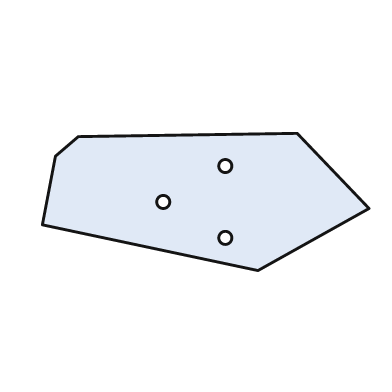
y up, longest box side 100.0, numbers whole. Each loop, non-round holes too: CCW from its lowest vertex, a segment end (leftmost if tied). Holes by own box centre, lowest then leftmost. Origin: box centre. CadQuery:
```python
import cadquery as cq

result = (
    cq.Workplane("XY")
    .moveTo(16.0, -21.0)
    .lineTo(50.0, -2.0)
    .lineTo(28.0, 21.0)
    .lineTo(-39.0, 20.0)
    .lineTo(-46.0, 14.0)
    .lineTo(-50.0, -7.0)
    .close()
    .moveTo(6.0, -11.0)
    .circle(2.0)
    .moveTo(-13.0, 0.0)
    .circle(2.0)
    .moveTo(6.0, 11.0)
    .circle(2.0)
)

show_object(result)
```